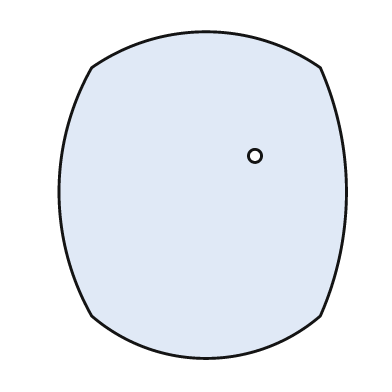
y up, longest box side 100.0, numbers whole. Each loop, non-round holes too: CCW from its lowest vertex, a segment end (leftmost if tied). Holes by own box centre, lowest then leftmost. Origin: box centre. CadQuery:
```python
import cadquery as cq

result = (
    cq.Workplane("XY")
    .moveTo(-34.0, -37.0)
    .threePointArc((1.0, -50.0), (36.0, -37.0))
    .threePointArc((44.0, 1.0), (36.0, 39.0))
    .threePointArc((1.0, 50.0), (-34.0, 39.0))
    .threePointArc((-44.0, 1.0), (-34.0, -37.0))
    .close()
    .moveTo(16.0, 12.0)
    .circle(2.0)
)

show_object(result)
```